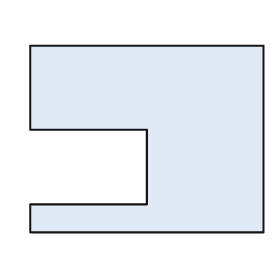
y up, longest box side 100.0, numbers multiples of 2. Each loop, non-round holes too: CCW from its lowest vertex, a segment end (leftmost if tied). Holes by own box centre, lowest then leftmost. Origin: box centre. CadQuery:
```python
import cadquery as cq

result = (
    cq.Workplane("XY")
    .moveTo(-50.0, -40.0)
    .lineTo(50.0, -40.0)
    .lineTo(50.0, 40.0)
    .lineTo(-50.0, 40.0)
    .lineTo(-50.0, 4.0)
    .lineTo(0.0, 4.0)
    .lineTo(0.0, -28.0)
    .lineTo(-50.0, -28.0)
    .close()
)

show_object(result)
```